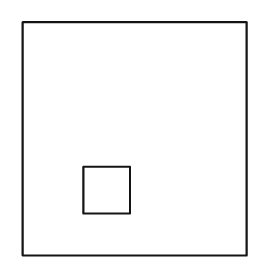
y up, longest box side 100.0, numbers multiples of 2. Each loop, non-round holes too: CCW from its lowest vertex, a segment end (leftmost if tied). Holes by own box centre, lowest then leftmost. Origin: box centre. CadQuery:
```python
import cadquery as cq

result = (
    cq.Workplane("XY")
    .moveTo(-48.0, -50.0)
    .lineTo(48.0, -50.0)
    .lineTo(48.0, 50.0)
    .lineTo(-48.0, 50.0)
    .close()
    .moveTo(-22.0, -32.0)
    .lineTo(-2.0, -32.0)
    .lineTo(-2.0, -12.0)
    .lineTo(-22.0, -12.0)
    .close()
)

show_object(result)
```